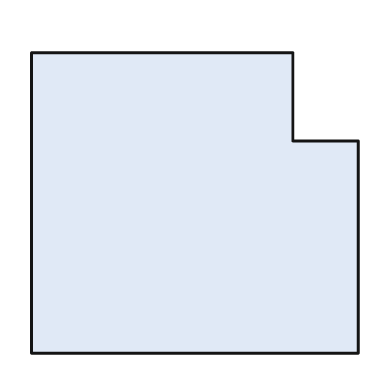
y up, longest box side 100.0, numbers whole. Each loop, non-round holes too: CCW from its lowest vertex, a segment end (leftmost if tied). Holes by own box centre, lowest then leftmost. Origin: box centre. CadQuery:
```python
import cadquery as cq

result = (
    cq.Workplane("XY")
    .moveTo(-50.0, -46.0)
    .lineTo(50.0, -46.0)
    .lineTo(50.0, 19.0)
    .lineTo(30.0, 19.0)
    .lineTo(30.0, 46.0)
    .lineTo(-50.0, 46.0)
    .close()
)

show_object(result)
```